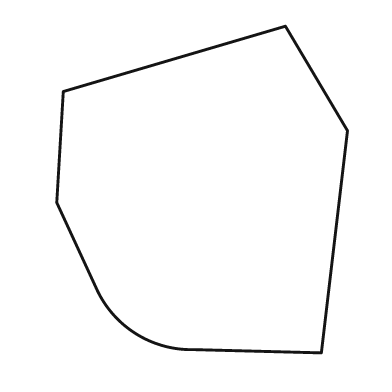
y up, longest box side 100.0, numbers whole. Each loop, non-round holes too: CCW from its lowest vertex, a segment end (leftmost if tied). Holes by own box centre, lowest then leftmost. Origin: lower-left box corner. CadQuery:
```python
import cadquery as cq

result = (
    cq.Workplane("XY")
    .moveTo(81.0, 0.0)
    .lineTo(89.0, 68.0)
    .lineTo(70.0, 100.0)
    .lineTo(2.0, 80.0)
    .lineTo(0.0, 46.0)
    .lineTo(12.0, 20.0)
    .threePointArc((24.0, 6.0), (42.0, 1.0))
    .close()
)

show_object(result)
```